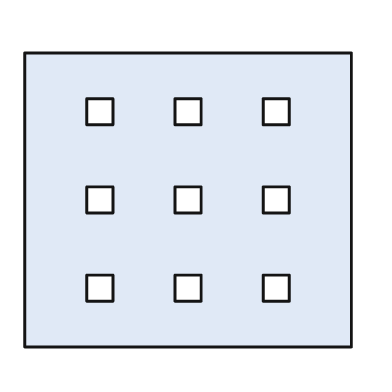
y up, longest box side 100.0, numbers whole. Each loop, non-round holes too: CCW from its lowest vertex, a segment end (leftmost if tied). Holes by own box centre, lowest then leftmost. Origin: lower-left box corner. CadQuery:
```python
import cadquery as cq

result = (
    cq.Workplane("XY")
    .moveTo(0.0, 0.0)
    .lineTo(100.0, 0.0)
    .lineTo(100.0, 90.0)
    .lineTo(0.0, 90.0)
    .close()
    .moveTo(19.0, 14.0)
    .lineTo(27.0, 14.0)
    .lineTo(27.0, 22.0)
    .lineTo(19.0, 22.0)
    .close()
    .moveTo(46.0, 14.0)
    .lineTo(54.0, 14.0)
    .lineTo(54.0, 22.0)
    .lineTo(46.0, 22.0)
    .close()
    .moveTo(73.0, 14.0)
    .lineTo(81.0, 14.0)
    .lineTo(81.0, 22.0)
    .lineTo(73.0, 22.0)
    .close()
    .moveTo(19.0, 41.0)
    .lineTo(27.0, 41.0)
    .lineTo(27.0, 49.0)
    .lineTo(19.0, 49.0)
    .close()
    .moveTo(46.0, 41.0)
    .lineTo(54.0, 41.0)
    .lineTo(54.0, 49.0)
    .lineTo(46.0, 49.0)
    .close()
    .moveTo(73.0, 41.0)
    .lineTo(81.0, 41.0)
    .lineTo(81.0, 49.0)
    .lineTo(73.0, 49.0)
    .close()
    .moveTo(19.0, 68.0)
    .lineTo(27.0, 68.0)
    .lineTo(27.0, 76.0)
    .lineTo(19.0, 76.0)
    .close()
    .moveTo(46.0, 68.0)
    .lineTo(54.0, 68.0)
    .lineTo(54.0, 76.0)
    .lineTo(46.0, 76.0)
    .close()
    .moveTo(73.0, 68.0)
    .lineTo(81.0, 68.0)
    .lineTo(81.0, 76.0)
    .lineTo(73.0, 76.0)
    .close()
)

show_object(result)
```